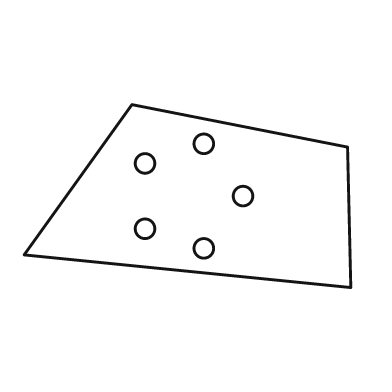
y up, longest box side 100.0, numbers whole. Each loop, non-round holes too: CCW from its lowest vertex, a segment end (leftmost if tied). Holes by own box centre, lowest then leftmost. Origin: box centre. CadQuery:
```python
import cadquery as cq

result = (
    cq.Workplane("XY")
    .moveTo(50.0, -28.0)
    .lineTo(49.0, 15.0)
    .lineTo(-17.0, 28.0)
    .lineTo(-50.0, -18.0)
    .close()
    .moveTo(5.0, -16.0)
    .circle(3.0)
    .moveTo(-13.0, -10.0)
    .circle(3.0)
    .moveTo(17.0, 0.0)
    .circle(3.0)
    .moveTo(-13.0, 10.0)
    .circle(3.0)
    .moveTo(5.0, 16.0)
    .circle(3.0)
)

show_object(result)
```